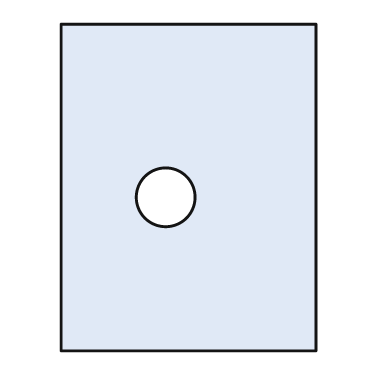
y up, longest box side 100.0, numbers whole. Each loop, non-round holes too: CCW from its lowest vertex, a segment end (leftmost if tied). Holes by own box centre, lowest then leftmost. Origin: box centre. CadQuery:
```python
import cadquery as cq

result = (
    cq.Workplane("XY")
    .moveTo(-39.0, -50.0)
    .lineTo(39.0, -50.0)
    .lineTo(39.0, 50.0)
    .lineTo(-39.0, 50.0)
    .close()
    .moveTo(-7.0, -3.0)
    .circle(9.0)
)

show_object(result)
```